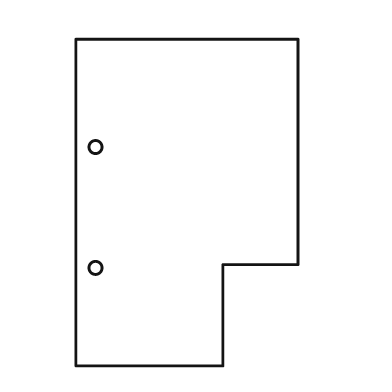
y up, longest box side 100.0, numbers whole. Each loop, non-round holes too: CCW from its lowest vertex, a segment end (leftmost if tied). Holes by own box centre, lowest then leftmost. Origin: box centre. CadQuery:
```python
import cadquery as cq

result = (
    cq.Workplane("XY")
    .moveTo(-34.0, -50.0)
    .lineTo(11.0, -50.0)
    .lineTo(11.0, -19.0)
    .lineTo(34.0, -19.0)
    .lineTo(34.0, 50.0)
    .lineTo(-34.0, 50.0)
    .close()
    .moveTo(-28.0, -20.0)
    .circle(2.0)
    .moveTo(-28.0, 17.0)
    .circle(2.0)
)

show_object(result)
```